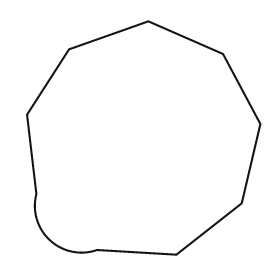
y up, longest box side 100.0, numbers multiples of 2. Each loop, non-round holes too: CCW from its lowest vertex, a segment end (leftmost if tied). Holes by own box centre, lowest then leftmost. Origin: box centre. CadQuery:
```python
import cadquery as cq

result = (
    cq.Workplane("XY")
    .moveTo(14.0, -50.0)
    .lineTo(42.0, -28.0)
    .lineTo(50.0, 6.0)
    .lineTo(34.0, 36.0)
    .lineTo(2.0, 50.0)
    .lineTo(-32.0, 38.0)
    .lineTo(-50.0, 10.0)
    .lineTo(-46.0, -24.0)
    .threePointArc((-40.0, -44.0), (-20.0, -48.0))
    .close()
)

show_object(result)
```